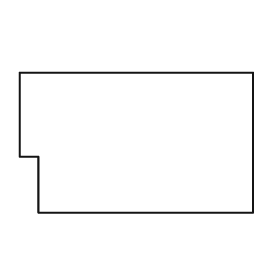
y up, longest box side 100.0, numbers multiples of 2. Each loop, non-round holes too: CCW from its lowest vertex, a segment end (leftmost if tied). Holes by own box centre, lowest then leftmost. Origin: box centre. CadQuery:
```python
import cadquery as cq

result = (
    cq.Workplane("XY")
    .moveTo(-42.0, -30.0)
    .lineTo(50.0, -30.0)
    .lineTo(50.0, 30.0)
    .lineTo(-50.0, 30.0)
    .lineTo(-50.0, -6.0)
    .lineTo(-42.0, -6.0)
    .close()
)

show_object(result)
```